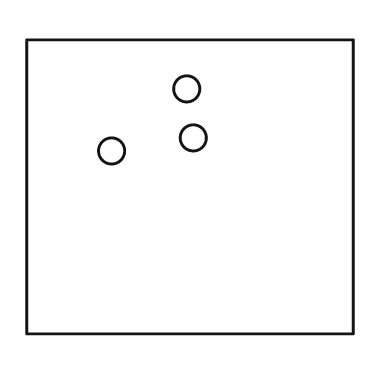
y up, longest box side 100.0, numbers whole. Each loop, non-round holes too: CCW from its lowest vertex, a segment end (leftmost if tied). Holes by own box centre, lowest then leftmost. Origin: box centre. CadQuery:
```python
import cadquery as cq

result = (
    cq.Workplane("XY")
    .moveTo(-50.0, -45.0)
    .lineTo(50.0, -45.0)
    .lineTo(50.0, 45.0)
    .lineTo(-50.0, 45.0)
    .close()
    .moveTo(-24.0, 11.0)
    .circle(4.0)
    .moveTo(1.0, 15.0)
    .circle(4.0)
    .moveTo(-1.0, 30.0)
    .circle(4.0)
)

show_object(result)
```